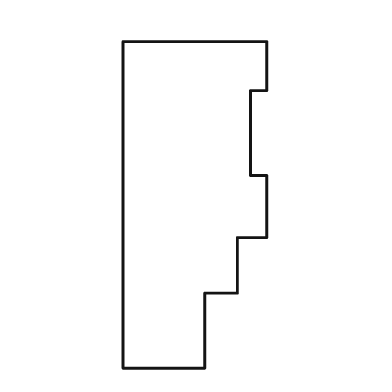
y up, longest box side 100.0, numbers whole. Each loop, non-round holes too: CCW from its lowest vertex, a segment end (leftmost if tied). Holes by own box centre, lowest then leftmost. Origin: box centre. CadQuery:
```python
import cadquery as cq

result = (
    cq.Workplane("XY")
    .moveTo(-22.0, -50.0)
    .lineTo(3.0, -50.0)
    .lineTo(3.0, -27.0)
    .lineTo(13.0, -27.0)
    .lineTo(13.0, -10.0)
    .lineTo(22.0, -10.0)
    .lineTo(22.0, 9.0)
    .lineTo(17.0, 9.0)
    .lineTo(17.0, 35.0)
    .lineTo(22.0, 35.0)
    .lineTo(22.0, 50.0)
    .lineTo(-22.0, 50.0)
    .close()
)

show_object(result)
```